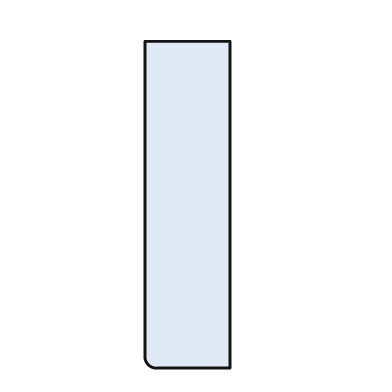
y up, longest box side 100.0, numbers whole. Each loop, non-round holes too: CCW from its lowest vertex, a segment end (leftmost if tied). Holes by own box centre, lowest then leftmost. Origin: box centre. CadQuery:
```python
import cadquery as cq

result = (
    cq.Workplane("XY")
    .moveTo(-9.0, -50.0)
    .lineTo(13.0, -50.0)
    .lineTo(13.0, 50.0)
    .lineTo(-13.0, 50.0)
    .lineTo(-13.0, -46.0)
    .threePointArc((-12.0, -49.0), (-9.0, -50.0))
    .close()
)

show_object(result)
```